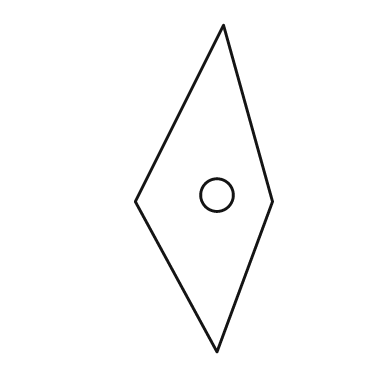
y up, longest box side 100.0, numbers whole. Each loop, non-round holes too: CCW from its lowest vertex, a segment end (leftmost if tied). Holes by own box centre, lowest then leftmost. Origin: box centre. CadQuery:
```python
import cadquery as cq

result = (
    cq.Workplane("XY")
    .moveTo(4.0, -50.0)
    .lineTo(21.0, -4.0)
    .lineTo(6.0, 50.0)
    .lineTo(-21.0, -4.0)
    .close()
    .moveTo(4.0, -2.0)
    .circle(5.0)
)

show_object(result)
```